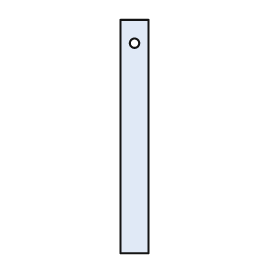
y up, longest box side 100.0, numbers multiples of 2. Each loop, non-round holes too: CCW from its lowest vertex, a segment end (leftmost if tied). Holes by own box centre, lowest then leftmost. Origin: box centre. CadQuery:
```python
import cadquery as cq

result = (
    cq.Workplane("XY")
    .moveTo(-6.0, -50.0)
    .lineTo(6.0, -50.0)
    .lineTo(6.0, 50.0)
    .lineTo(-6.0, 50.0)
    .close()
    .moveTo(0.0, 40.0)
    .circle(2.0)
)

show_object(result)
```